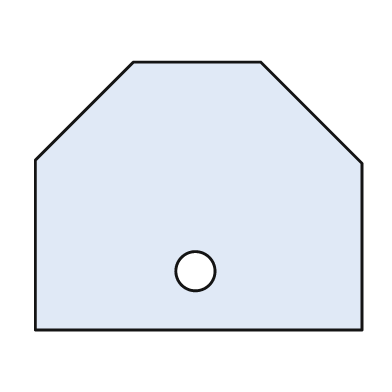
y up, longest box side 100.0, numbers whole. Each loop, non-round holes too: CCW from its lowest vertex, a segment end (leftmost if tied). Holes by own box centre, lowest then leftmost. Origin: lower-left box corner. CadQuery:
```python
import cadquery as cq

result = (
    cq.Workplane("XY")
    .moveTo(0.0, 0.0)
    .lineTo(100.0, 0.0)
    .lineTo(100.0, 51.0)
    .lineTo(69.0, 82.0)
    .lineTo(30.0, 82.0)
    .lineTo(0.0, 52.0)
    .close()
    .moveTo(49.0, 18.0)
    .circle(6.0)
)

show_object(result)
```